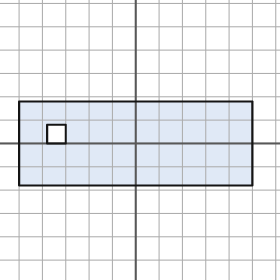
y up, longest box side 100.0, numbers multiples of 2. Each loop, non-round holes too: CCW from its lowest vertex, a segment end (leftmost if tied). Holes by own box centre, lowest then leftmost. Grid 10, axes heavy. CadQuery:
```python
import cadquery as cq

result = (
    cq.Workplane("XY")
    .moveTo(-50.0, -18.0)
    .lineTo(50.0, -18.0)
    .lineTo(50.0, 18.0)
    .lineTo(-50.0, 18.0)
    .close()
    .moveTo(-38.0, 0.0)
    .lineTo(-30.0, 0.0)
    .lineTo(-30.0, 8.0)
    .lineTo(-38.0, 8.0)
    .close()
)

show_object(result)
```